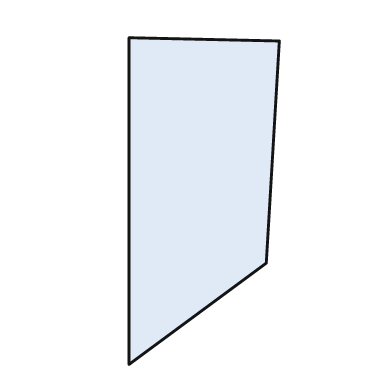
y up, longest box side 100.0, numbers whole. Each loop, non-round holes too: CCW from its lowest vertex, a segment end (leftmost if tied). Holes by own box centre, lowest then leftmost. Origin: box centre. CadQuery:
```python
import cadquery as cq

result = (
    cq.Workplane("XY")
    .moveTo(-23.0, -50.0)
    .lineTo(19.0, -19.0)
    .lineTo(23.0, 49.0)
    .lineTo(-23.0, 50.0)
    .close()
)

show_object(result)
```